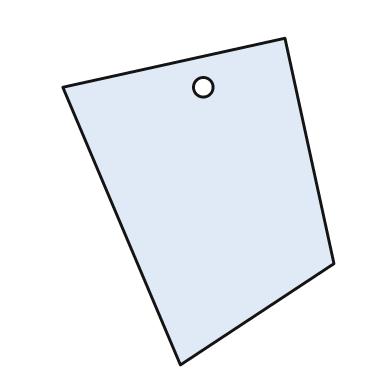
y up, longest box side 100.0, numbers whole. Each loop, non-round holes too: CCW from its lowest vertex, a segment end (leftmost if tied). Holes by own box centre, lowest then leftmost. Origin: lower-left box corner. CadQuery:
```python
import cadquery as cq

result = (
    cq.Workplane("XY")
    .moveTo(36.0, 0.0)
    .lineTo(83.0, 31.0)
    .lineTo(68.0, 100.0)
    .lineTo(0.0, 85.0)
    .close()
    .moveTo(43.0, 85.0)
    .circle(3.0)
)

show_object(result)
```